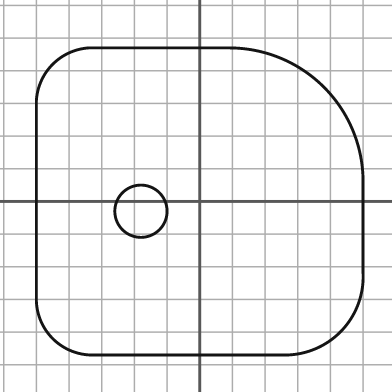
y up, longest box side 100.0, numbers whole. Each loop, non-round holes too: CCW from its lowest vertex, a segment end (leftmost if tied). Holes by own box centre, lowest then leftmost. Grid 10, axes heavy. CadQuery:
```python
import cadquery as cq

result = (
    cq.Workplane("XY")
    .moveTo(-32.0, -47.0)
    .lineTo(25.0, -47.0)
    .threePointArc((43.0, -40.0), (50.0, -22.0))
    .lineTo(50.0, 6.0)
    .threePointArc((38.0, 35.0), (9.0, 47.0))
    .lineTo(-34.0, 47.0)
    .threePointArc((-45.0, 42.0), (-50.0, 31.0))
    .lineTo(-50.0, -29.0)
    .threePointArc((-45.0, -42.0), (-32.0, -47.0))
    .close()
    .moveTo(-18.0, -3.0)
    .circle(8.0)
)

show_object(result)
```